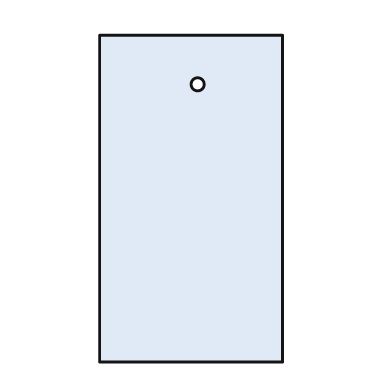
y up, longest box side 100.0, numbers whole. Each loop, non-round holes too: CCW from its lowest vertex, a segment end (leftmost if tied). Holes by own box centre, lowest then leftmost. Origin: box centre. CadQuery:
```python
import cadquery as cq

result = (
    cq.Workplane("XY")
    .moveTo(-28.0, -50.0)
    .lineTo(28.0, -50.0)
    .lineTo(28.0, 50.0)
    .lineTo(-28.0, 50.0)
    .close()
    .moveTo(2.0, 35.0)
    .circle(2.0)
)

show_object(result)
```